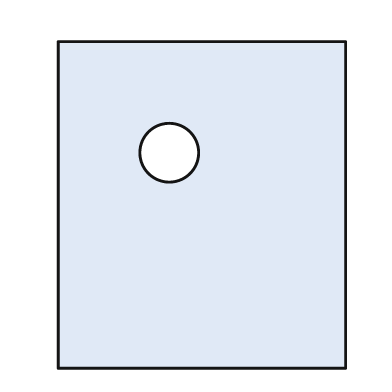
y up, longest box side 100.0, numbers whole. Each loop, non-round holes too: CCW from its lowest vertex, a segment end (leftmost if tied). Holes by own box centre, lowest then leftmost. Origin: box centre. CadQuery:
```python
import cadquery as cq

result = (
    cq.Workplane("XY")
    .moveTo(-44.0, -50.0)
    .lineTo(44.0, -50.0)
    .lineTo(44.0, 50.0)
    .lineTo(-44.0, 50.0)
    .close()
    .moveTo(-10.0, 16.0)
    .circle(9.0)
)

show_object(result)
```